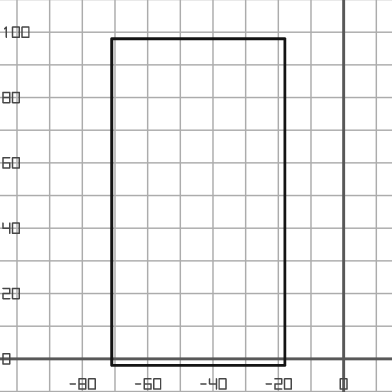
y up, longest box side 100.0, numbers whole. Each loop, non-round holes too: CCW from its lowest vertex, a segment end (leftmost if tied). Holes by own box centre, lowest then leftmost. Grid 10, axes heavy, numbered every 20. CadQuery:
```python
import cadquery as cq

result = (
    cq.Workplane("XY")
    .moveTo(-71.0, -2.0)
    .lineTo(-18.0, -2.0)
    .lineTo(-18.0, 98.0)
    .lineTo(-71.0, 98.0)
    .close()
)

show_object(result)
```